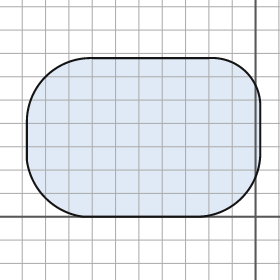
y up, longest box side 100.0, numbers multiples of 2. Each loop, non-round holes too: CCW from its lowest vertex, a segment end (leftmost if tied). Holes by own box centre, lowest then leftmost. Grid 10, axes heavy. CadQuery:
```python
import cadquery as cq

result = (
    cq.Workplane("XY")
    .moveTo(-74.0, 0.0)
    .lineTo(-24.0, 0.0)
    .threePointArc((-6.0, 8.0), (2.0, 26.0))
    .lineTo(2.0, 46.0)
    .threePointArc((-4.0, 62.0), (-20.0, 68.0))
    .lineTo(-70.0, 68.0)
    .threePointArc((-90.0, 60.0), (-98.0, 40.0))
    .lineTo(-98.0, 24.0)
    .threePointArc((-90.0, 8.0), (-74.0, 0.0))
    .close()
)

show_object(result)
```